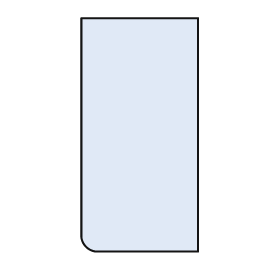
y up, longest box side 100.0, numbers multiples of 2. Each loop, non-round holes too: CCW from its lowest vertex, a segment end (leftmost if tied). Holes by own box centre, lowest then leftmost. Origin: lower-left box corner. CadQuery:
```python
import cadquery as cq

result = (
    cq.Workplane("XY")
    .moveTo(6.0, 0.0)
    .lineTo(50.0, 0.0)
    .lineTo(50.0, 100.0)
    .lineTo(0.0, 100.0)
    .lineTo(0.0, 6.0)
    .threePointArc((2.0, 2.0), (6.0, 0.0))
    .close()
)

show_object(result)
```